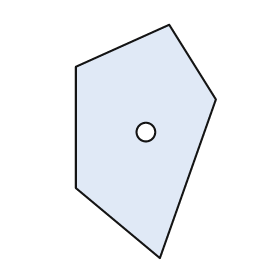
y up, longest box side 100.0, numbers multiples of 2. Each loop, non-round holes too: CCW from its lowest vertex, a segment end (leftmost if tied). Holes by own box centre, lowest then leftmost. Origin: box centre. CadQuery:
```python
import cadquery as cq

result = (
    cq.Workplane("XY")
    .moveTo(6.0, -50.0)
    .lineTo(30.0, 18.0)
    .lineTo(10.0, 50.0)
    .lineTo(-30.0, 32.0)
    .lineTo(-30.0, -20.0)
    .close()
    .moveTo(0.0, 4.0)
    .circle(4.0)
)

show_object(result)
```